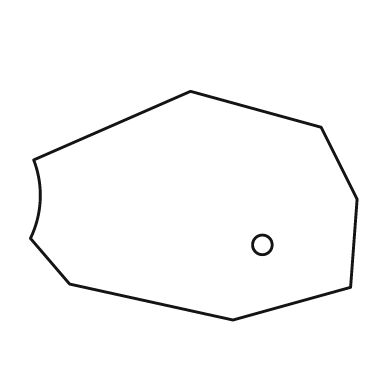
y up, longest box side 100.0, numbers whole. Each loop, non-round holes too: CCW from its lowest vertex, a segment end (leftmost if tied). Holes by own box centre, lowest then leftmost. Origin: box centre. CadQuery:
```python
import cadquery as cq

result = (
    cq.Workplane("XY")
    .moveTo(12.0, -35.0)
    .lineTo(48.0, -25.0)
    .lineTo(50.0, 2.0)
    .lineTo(39.0, 24.0)
    .lineTo(-1.0, 35.0)
    .lineTo(-49.0, 14.0)
    .threePointArc((-47.0, 2.0), (-50.0, -10.0))
    .lineTo(-38.0, -24.0)
    .close()
    .moveTo(21.0, -12.0)
    .circle(3.0)
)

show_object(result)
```